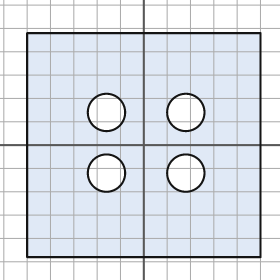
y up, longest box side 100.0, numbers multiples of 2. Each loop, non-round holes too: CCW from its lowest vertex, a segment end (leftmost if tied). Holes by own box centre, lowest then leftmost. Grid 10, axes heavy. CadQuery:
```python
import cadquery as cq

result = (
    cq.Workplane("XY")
    .moveTo(-50.0, -48.0)
    .lineTo(50.0, -48.0)
    .lineTo(50.0, 48.0)
    .lineTo(-50.0, 48.0)
    .close()
    .moveTo(-16.0, -12.0)
    .circle(8.0)
    .moveTo(18.0, -12.0)
    .circle(8.0)
    .moveTo(-16.0, 14.0)
    .circle(8.0)
    .moveTo(18.0, 14.0)
    .circle(8.0)
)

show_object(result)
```